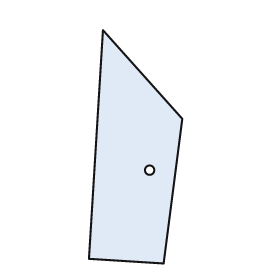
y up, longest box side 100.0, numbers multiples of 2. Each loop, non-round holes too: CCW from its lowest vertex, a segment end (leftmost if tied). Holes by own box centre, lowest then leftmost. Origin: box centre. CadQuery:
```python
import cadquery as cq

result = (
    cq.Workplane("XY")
    .moveTo(12.0, -50.0)
    .lineTo(20.0, 12.0)
    .lineTo(-14.0, 50.0)
    .lineTo(-20.0, -48.0)
    .close()
    .moveTo(6.0, -10.0)
    .circle(2.0)
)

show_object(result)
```